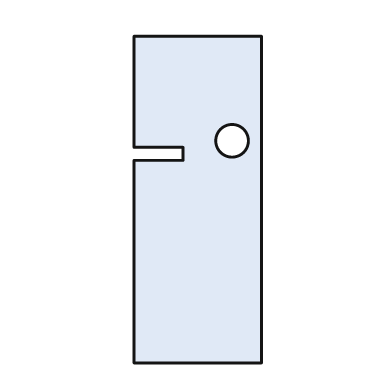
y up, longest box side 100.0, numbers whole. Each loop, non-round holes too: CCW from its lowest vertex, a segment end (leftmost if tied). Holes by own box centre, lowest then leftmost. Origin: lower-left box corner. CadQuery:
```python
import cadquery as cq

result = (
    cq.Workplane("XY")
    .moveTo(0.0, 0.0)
    .lineTo(39.0, 0.0)
    .lineTo(39.0, 100.0)
    .lineTo(0.0, 100.0)
    .lineTo(0.0, 66.0)
    .lineTo(15.0, 66.0)
    .lineTo(15.0, 62.0)
    .lineTo(0.0, 62.0)
    .close()
    .moveTo(30.0, 68.0)
    .circle(5.0)
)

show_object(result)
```